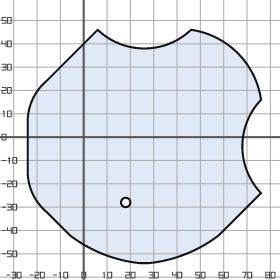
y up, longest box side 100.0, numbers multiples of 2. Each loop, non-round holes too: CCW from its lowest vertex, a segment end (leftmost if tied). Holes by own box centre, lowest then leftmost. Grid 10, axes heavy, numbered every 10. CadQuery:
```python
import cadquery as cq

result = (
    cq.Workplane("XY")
    .moveTo(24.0, -54.0)
    .lineTo(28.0, -54.0)
    .threePointArc((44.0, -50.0), (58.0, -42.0))
    .lineTo(76.0, -24.0)
    .threePointArc((68.0, -4.0), (76.0, 16.0))
    .threePointArc((66.0, 36.0), (46.0, 46.0))
    .threePointArc((26.0, 38.0), (6.0, 46.0))
    .lineTo(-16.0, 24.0)
    .threePointArc((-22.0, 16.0), (-24.0, 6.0))
    .lineTo(-24.0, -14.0)
    .threePointArc((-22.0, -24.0), (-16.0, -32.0))
    .lineTo(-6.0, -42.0)
    .threePointArc((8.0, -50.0), (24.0, -54.0))
    .close()
    .moveTo(18.0, -28.0)
    .circle(2.0)
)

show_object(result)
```